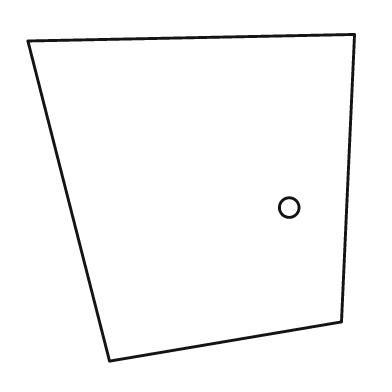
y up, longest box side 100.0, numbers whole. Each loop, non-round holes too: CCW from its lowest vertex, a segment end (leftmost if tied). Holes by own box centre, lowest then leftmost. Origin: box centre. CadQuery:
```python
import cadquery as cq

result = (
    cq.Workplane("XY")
    .moveTo(-25.0, -50.0)
    .lineTo(46.0, -38.0)
    .lineTo(50.0, 50.0)
    .lineTo(-50.0, 48.0)
    .close()
    .moveTo(30.0, -3.0)
    .circle(3.0)
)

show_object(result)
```